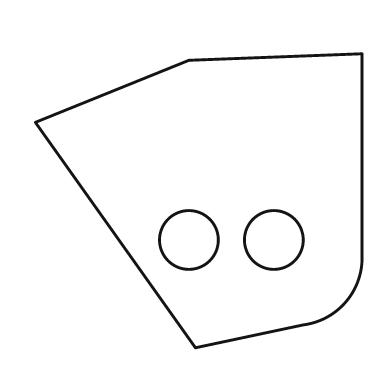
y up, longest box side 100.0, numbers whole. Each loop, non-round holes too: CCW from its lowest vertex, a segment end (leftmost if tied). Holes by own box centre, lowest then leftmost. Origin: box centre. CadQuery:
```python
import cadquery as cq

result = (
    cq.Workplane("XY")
    .moveTo(-1.0, -45.0)
    .lineTo(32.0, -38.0)
    .threePointArc((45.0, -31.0), (50.0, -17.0))
    .lineTo(50.0, 45.0)
    .lineTo(-3.0, 43.0)
    .lineTo(-50.0, 24.0)
    .close()
    .moveTo(-3.0, -12.0)
    .circle(9.0)
    .moveTo(23.0, -12.0)
    .circle(9.0)
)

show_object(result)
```